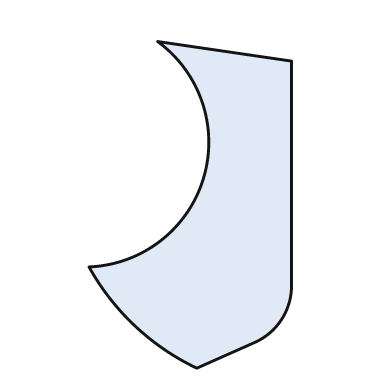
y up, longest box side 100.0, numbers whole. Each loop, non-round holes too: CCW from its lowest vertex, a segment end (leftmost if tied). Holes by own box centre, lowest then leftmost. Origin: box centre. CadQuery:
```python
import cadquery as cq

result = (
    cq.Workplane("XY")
    .moveTo(2.0, -50.0)
    .lineTo(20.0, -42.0)
    .threePointArc((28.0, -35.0), (31.0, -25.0))
    .lineTo(31.0, 44.0)
    .lineTo(-10.0, 50.0)
    .threePointArc((4.0, 8.0), (-31.0, -19.0))
    .threePointArc((-17.0, -37.0), (2.0, -50.0))
    .close()
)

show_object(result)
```